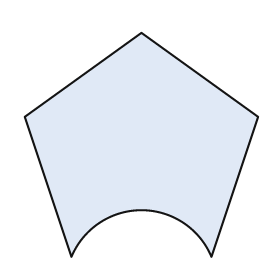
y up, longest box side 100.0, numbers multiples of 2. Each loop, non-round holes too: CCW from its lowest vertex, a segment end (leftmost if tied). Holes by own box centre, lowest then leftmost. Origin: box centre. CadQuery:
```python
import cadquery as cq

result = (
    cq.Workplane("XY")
    .moveTo(-30.0, -48.0)
    .threePointArc((0.0, -28.0), (30.0, -48.0))
    .lineTo(50.0, 12.0)
    .lineTo(0.0, 48.0)
    .lineTo(-50.0, 12.0)
    .close()
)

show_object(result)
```